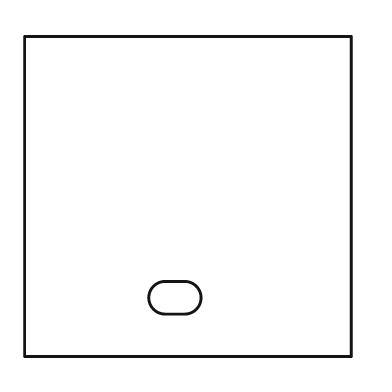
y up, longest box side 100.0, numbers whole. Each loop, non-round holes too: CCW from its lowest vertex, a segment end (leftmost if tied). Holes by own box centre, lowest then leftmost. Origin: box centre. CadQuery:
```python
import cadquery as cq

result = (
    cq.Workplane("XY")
    .moveTo(-50.0, -49.0)
    .lineTo(50.0, -49.0)
    .lineTo(50.0, 49.0)
    .lineTo(-50.0, 49.0)
    .close()
    .moveTo(-7.0, -36.0)
    .lineTo(-1.0, -36.0)
    .threePointArc((4.0, -31.0), (-1.0, -26.0))
    .lineTo(-7.0, -26.0)
    .threePointArc((-12.0, -31.0), (-7.0, -36.0))
    .close()
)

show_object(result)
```